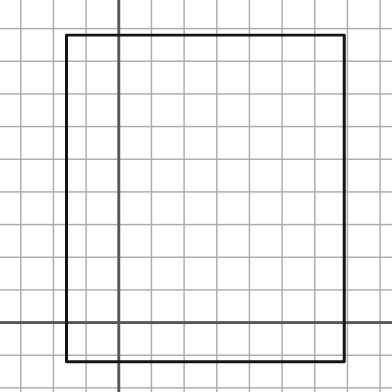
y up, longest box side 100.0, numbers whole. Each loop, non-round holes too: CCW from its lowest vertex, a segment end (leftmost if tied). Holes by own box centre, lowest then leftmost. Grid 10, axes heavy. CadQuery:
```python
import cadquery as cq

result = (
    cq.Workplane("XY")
    .moveTo(-16.0, -12.0)
    .lineTo(69.0, -12.0)
    .lineTo(69.0, 88.0)
    .lineTo(-16.0, 88.0)
    .close()
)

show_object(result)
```